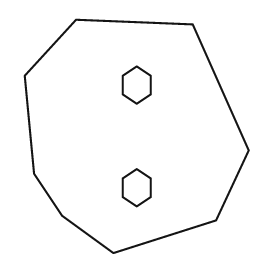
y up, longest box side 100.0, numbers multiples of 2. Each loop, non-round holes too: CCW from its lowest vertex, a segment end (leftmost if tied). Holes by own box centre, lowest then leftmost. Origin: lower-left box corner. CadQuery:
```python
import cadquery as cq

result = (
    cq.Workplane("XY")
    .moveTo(38.0, 0.0)
    .lineTo(82.0, 14.0)
    .lineTo(96.0, 44.0)
    .lineTo(72.0, 98.0)
    .lineTo(22.0, 100.0)
    .lineTo(0.0, 76.0)
    .lineTo(4.0, 34.0)
    .lineTo(16.0, 16.0)
    .close()
    .moveTo(48.0, 20.0)
    .lineTo(54.0, 24.0)
    .lineTo(54.0, 32.0)
    .lineTo(48.0, 36.0)
    .lineTo(42.0, 32.0)
    .lineTo(42.0, 24.0)
    .close()
    .moveTo(48.0, 64.0)
    .lineTo(54.0, 68.0)
    .lineTo(54.0, 76.0)
    .lineTo(48.0, 80.0)
    .lineTo(42.0, 76.0)
    .lineTo(42.0, 68.0)
    .close()
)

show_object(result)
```